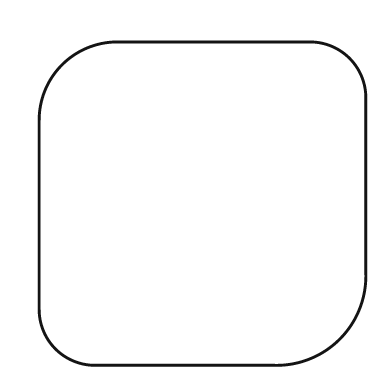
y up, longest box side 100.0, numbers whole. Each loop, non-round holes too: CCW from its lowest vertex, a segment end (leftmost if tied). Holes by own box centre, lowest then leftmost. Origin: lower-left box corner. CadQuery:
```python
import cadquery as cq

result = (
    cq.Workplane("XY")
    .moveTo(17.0, 0.0)
    .lineTo(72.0, 0.0)
    .threePointArc((92.0, 8.0), (100.0, 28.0))
    .lineTo(100.0, 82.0)
    .threePointArc((95.0, 94.0), (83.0, 99.0))
    .lineTo(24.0, 99.0)
    .threePointArc((7.0, 92.0), (0.0, 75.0))
    .lineTo(0.0, 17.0)
    .threePointArc((5.0, 5.0), (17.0, 0.0))
    .close()
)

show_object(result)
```